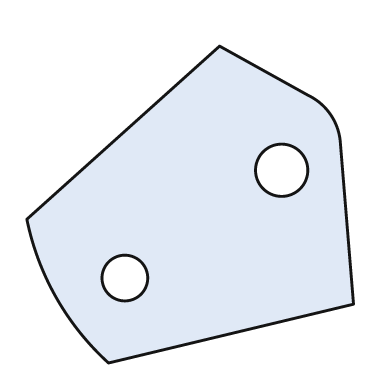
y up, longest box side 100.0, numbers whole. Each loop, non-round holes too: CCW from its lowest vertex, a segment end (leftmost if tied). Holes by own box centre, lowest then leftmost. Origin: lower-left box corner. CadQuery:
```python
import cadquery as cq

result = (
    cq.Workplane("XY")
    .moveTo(25.0, 0.0)
    .lineTo(100.0, 18.0)
    .lineTo(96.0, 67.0)
    .threePointArc((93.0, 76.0), (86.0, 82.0))
    .lineTo(59.0, 97.0)
    .lineTo(0.0, 44.0)
    .threePointArc((9.0, 20.0), (25.0, 0.0))
    .close()
    .moveTo(30.0, 26.0)
    .circle(7.0)
    .moveTo(78.0, 59.0)
    .circle(8.0)
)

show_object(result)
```